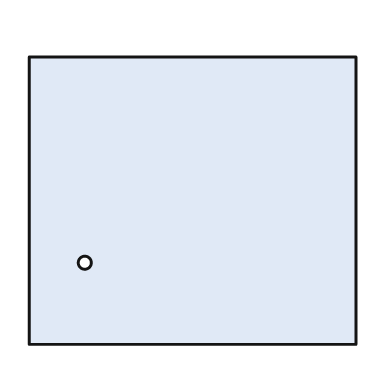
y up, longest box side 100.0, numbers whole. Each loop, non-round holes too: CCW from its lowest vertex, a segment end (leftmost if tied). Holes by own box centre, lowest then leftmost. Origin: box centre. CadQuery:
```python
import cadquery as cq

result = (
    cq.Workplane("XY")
    .moveTo(-50.0, -44.0)
    .lineTo(50.0, -44.0)
    .lineTo(50.0, 44.0)
    .lineTo(-50.0, 44.0)
    .close()
    .moveTo(-33.0, -19.0)
    .circle(2.0)
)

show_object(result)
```